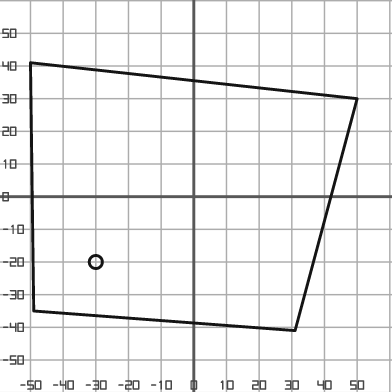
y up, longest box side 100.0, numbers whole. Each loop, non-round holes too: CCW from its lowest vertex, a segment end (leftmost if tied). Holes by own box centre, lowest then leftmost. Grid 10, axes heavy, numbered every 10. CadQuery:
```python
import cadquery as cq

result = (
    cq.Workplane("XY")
    .moveTo(31.0, -41.0)
    .lineTo(50.0, 30.0)
    .lineTo(-50.0, 41.0)
    .lineTo(-49.0, -35.0)
    .close()
    .moveTo(-30.0, -20.0)
    .circle(2.0)
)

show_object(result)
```